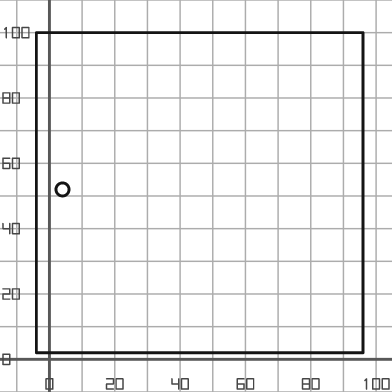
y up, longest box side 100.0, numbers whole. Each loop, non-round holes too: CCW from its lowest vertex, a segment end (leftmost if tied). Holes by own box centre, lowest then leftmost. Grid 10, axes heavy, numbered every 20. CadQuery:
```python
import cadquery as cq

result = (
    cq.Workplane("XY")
    .moveTo(-4.0, 2.0)
    .lineTo(96.0, 2.0)
    .lineTo(96.0, 100.0)
    .lineTo(-4.0, 100.0)
    .close()
    .moveTo(4.0, 52.0)
    .circle(2.0)
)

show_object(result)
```